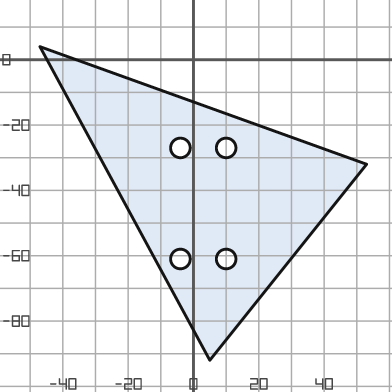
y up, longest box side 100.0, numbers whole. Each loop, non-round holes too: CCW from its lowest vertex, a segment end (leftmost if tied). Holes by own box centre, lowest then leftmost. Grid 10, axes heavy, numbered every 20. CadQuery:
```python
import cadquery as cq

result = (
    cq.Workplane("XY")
    .moveTo(5.0, -92.0)
    .lineTo(53.0, -32.0)
    .lineTo(-47.0, 4.0)
    .close()
    .moveTo(-4.0, -61.0)
    .circle(3.0)
    .moveTo(10.0, -61.0)
    .circle(3.0)
    .moveTo(-4.0, -27.0)
    .circle(3.0)
    .moveTo(10.0, -27.0)
    .circle(3.0)
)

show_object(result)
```